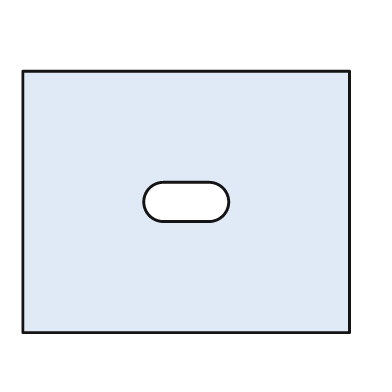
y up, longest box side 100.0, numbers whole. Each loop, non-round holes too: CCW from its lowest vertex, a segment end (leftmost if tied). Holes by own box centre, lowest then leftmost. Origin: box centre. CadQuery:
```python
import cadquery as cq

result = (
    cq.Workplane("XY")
    .moveTo(-50.0, -40.0)
    .lineTo(50.0, -40.0)
    .lineTo(50.0, 40.0)
    .lineTo(-50.0, 40.0)
    .close()
    .moveTo(-7.0, -6.0)
    .lineTo(7.0, -6.0)
    .threePointArc((13.0, 0.0), (7.0, 6.0))
    .lineTo(-7.0, 6.0)
    .threePointArc((-13.0, 0.0), (-7.0, -6.0))
    .close()
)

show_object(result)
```